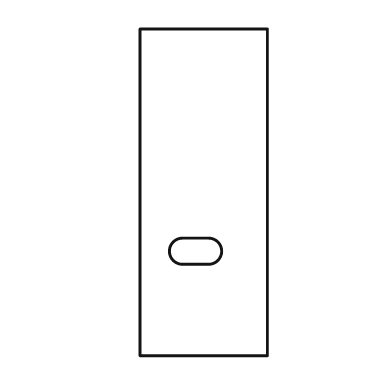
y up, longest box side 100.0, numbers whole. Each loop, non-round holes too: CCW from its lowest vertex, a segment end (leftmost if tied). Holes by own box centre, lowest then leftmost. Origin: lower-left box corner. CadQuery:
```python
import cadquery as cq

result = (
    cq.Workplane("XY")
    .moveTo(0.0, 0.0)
    .lineTo(39.0, 0.0)
    .lineTo(39.0, 100.0)
    .lineTo(0.0, 100.0)
    .close()
    .moveTo(13.0, 28.0)
    .lineTo(21.0, 28.0)
    .threePointArc((25.0, 32.0), (21.0, 36.0))
    .lineTo(13.0, 36.0)
    .threePointArc((9.0, 32.0), (13.0, 28.0))
    .close()
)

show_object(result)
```